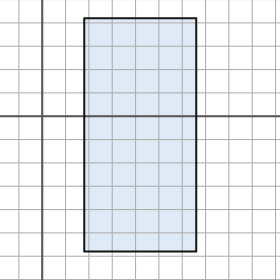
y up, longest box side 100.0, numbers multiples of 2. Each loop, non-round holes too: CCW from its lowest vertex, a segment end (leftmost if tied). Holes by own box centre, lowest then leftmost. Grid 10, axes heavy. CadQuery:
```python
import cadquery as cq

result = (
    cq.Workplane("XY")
    .moveTo(18.0, -58.0)
    .lineTo(66.0, -58.0)
    .lineTo(66.0, 42.0)
    .lineTo(18.0, 42.0)
    .close()
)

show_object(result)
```